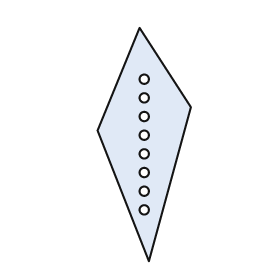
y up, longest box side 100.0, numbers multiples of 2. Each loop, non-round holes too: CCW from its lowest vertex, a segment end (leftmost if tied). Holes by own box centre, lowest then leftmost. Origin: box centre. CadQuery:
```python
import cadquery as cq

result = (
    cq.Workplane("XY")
    .moveTo(2.0, -50.0)
    .lineTo(20.0, 16.0)
    .lineTo(-2.0, 50.0)
    .lineTo(-20.0, 6.0)
    .close()
    .moveTo(0.0, -28.0)
    .circle(2.0)
    .moveTo(0.0, -20.0)
    .circle(2.0)
    .moveTo(0.0, -12.0)
    .circle(2.0)
    .moveTo(0.0, -4.0)
    .circle(2.0)
    .moveTo(0.0, 4.0)
    .circle(2.0)
    .moveTo(0.0, 12.0)
    .circle(2.0)
    .moveTo(0.0, 20.0)
    .circle(2.0)
    .moveTo(0.0, 28.0)
    .circle(2.0)
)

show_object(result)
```